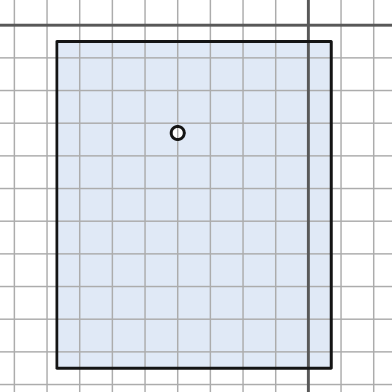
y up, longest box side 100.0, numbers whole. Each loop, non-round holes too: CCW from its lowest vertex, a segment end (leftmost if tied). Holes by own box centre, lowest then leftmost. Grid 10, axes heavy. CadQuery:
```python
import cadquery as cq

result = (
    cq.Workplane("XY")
    .moveTo(-77.0, -105.0)
    .lineTo(7.0, -105.0)
    .lineTo(7.0, -5.0)
    .lineTo(-77.0, -5.0)
    .close()
    .moveTo(-40.0, -33.0)
    .circle(2.0)
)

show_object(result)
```